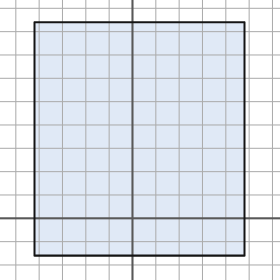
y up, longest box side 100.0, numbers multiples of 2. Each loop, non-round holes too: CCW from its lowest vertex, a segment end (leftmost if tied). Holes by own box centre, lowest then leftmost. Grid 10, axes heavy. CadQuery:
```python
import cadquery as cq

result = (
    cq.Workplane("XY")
    .moveTo(-42.0, -16.0)
    .lineTo(48.0, -16.0)
    .lineTo(48.0, 84.0)
    .lineTo(-42.0, 84.0)
    .close()
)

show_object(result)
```